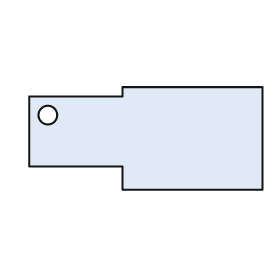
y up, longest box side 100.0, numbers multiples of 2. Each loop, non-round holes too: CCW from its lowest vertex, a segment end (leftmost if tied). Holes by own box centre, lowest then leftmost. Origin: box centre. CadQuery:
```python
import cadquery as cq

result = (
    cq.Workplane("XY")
    .moveTo(-10.0, -22.0)
    .lineTo(50.0, -22.0)
    .lineTo(50.0, 22.0)
    .lineTo(-10.0, 22.0)
    .lineTo(-10.0, 18.0)
    .lineTo(-50.0, 18.0)
    .lineTo(-50.0, -12.0)
    .lineTo(-10.0, -12.0)
    .close()
    .moveTo(-42.0, 10.0)
    .circle(4.0)
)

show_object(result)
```